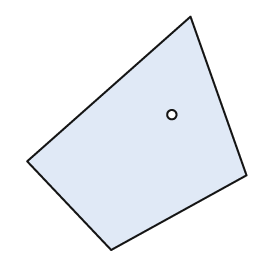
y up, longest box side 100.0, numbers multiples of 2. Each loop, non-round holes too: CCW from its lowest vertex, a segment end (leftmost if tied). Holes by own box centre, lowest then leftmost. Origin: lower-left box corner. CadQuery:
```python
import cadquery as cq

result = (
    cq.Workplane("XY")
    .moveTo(36.0, 0.0)
    .lineTo(94.0, 32.0)
    .lineTo(70.0, 100.0)
    .lineTo(0.0, 38.0)
    .close()
    .moveTo(62.0, 58.0)
    .circle(2.0)
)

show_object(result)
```